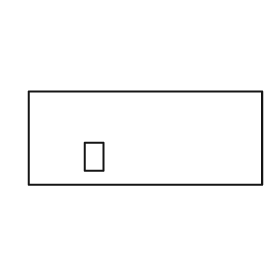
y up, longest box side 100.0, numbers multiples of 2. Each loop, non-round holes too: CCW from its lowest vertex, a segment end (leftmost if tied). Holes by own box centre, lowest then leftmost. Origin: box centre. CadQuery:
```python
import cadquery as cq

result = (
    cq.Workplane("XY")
    .moveTo(-50.0, -20.0)
    .lineTo(50.0, -20.0)
    .lineTo(50.0, 20.0)
    .lineTo(-50.0, 20.0)
    .close()
    .moveTo(-26.0, -14.0)
    .lineTo(-18.0, -14.0)
    .lineTo(-18.0, -2.0)
    .lineTo(-26.0, -2.0)
    .close()
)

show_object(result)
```